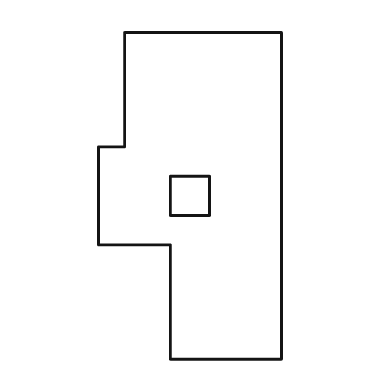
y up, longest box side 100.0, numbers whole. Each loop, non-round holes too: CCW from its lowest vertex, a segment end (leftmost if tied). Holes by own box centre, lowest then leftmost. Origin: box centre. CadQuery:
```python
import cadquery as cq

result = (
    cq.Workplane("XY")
    .moveTo(-6.0, -50.0)
    .lineTo(28.0, -50.0)
    .lineTo(28.0, 50.0)
    .lineTo(-20.0, 50.0)
    .lineTo(-20.0, 15.0)
    .lineTo(-28.0, 15.0)
    .lineTo(-28.0, -15.0)
    .lineTo(-6.0, -15.0)
    .close()
    .moveTo(-6.0, -6.0)
    .lineTo(6.0, -6.0)
    .lineTo(6.0, 6.0)
    .lineTo(-6.0, 6.0)
    .close()
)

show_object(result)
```